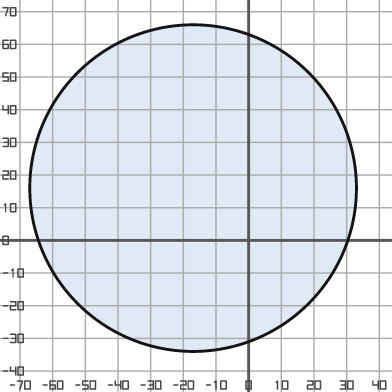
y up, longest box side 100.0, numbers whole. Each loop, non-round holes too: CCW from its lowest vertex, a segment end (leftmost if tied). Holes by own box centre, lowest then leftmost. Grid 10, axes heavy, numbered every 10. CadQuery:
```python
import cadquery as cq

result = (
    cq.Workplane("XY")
    .moveTo(-17.0, 16.0)
    .circle(50.0)
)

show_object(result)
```